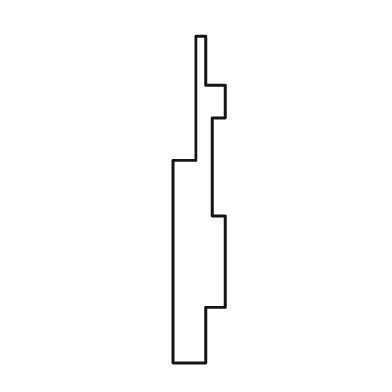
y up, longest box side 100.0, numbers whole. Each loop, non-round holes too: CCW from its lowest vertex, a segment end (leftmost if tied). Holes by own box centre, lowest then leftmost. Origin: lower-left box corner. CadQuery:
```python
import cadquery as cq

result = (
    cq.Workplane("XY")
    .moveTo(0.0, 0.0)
    .lineTo(10.0, 0.0)
    .lineTo(10.0, 17.0)
    .lineTo(16.0, 17.0)
    .lineTo(16.0, 45.0)
    .lineTo(12.0, 45.0)
    .lineTo(12.0, 75.0)
    .lineTo(16.0, 75.0)
    .lineTo(16.0, 85.0)
    .lineTo(10.0, 85.0)
    .lineTo(10.0, 100.0)
    .lineTo(7.0, 100.0)
    .lineTo(7.0, 62.0)
    .lineTo(0.0, 62.0)
    .close()
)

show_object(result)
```